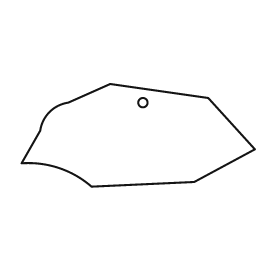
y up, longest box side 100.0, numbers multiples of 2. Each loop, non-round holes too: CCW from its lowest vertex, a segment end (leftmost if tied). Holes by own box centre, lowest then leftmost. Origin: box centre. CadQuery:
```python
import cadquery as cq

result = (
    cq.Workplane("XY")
    .moveTo(-20.0, -22.0)
    .lineTo(24.0, -20.0)
    .lineTo(50.0, -6.0)
    .lineTo(30.0, 16.0)
    .lineTo(-12.0, 22.0)
    .lineTo(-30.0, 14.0)
    .threePointArc((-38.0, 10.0), (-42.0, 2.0))
    .lineTo(-50.0, -12.0)
    .threePointArc((-34.0, -14.0), (-20.0, -22.0))
    .close()
    .moveTo(2.0, 14.0)
    .circle(2.0)
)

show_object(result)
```